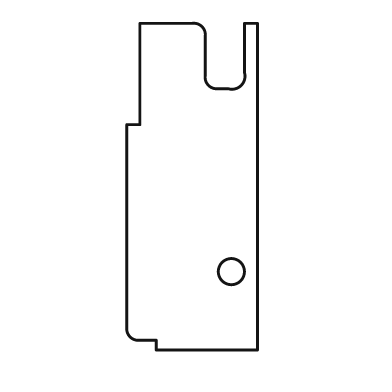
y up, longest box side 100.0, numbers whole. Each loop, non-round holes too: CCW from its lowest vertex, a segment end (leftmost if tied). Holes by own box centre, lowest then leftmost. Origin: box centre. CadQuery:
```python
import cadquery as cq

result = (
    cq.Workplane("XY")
    .moveTo(-11.0, -50.0)
    .lineTo(20.0, -50.0)
    .lineTo(20.0, 50.0)
    .lineTo(16.0, 50.0)
    .lineTo(16.0, 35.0)
    .threePointArc((15.0, 31.0), (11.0, 30.0))
    .lineTo(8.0, 30.0)
    .threePointArc((5.0, 31.0), (4.0, 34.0))
    .lineTo(4.0, 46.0)
    .threePointArc((3.0, 49.0), (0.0, 50.0))
    .lineTo(-16.0, 50.0)
    .lineTo(-16.0, 19.0)
    .lineTo(-20.0, 19.0)
    .lineTo(-20.0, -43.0)
    .threePointArc((-19.0, -46.0), (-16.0, -47.0))
    .lineTo(-11.0, -47.0)
    .close()
    .moveTo(12.0, -26.0)
    .circle(4.0)
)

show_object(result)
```